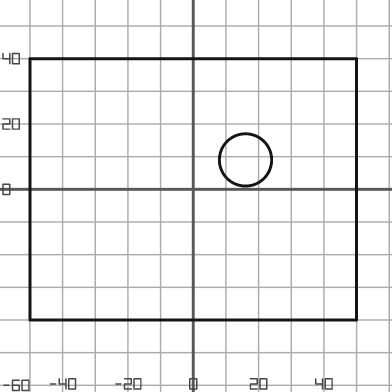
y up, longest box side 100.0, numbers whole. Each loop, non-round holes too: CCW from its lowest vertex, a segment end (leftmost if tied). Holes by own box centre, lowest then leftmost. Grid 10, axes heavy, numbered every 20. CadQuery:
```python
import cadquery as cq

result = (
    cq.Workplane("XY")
    .moveTo(-50.0, -40.0)
    .lineTo(50.0, -40.0)
    .lineTo(50.0, 40.0)
    .lineTo(-50.0, 40.0)
    .close()
    .moveTo(16.0, 9.0)
    .circle(8.0)
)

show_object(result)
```